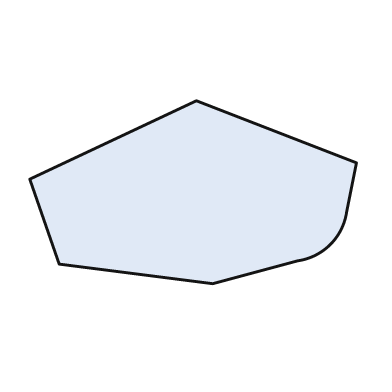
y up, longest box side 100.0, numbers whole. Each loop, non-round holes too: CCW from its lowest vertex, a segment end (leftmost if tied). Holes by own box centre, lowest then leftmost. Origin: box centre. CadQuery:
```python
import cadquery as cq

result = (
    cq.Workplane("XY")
    .moveTo(6.0, -28.0)
    .lineTo(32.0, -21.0)
    .threePointArc((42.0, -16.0), (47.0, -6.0))
    .lineTo(50.0, 9.0)
    .lineTo(1.0, 28.0)
    .lineTo(-50.0, 4.0)
    .lineTo(-41.0, -22.0)
    .close()
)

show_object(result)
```